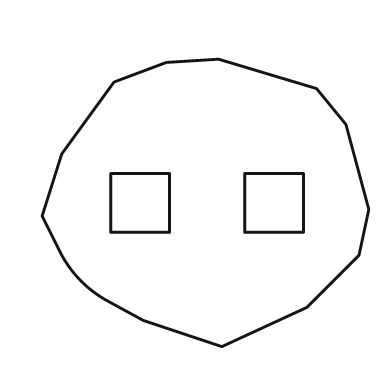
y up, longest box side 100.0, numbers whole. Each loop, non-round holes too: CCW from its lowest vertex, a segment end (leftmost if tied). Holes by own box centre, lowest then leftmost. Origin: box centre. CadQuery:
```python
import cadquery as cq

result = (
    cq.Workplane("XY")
    .moveTo(5.0, -44.0)
    .lineTo(31.0, -32.0)
    .lineTo(47.0, -16.0)
    .lineTo(50.0, -2.0)
    .lineTo(43.0, 24.0)
    .lineTo(34.0, 35.0)
    .lineTo(4.0, 44.0)
    .lineTo(-12.0, 43.0)
    .lineTo(-28.0, 37.0)
    .lineTo(-44.0, 15.0)
    .lineTo(-50.0, -4.0)
    .lineTo(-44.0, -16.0)
    .threePointArc((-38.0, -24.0), (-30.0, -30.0))
    .lineTo(-19.0, -36.0)
    .close()
    .moveTo(-29.0, -9.0)
    .lineTo(-11.0, -9.0)
    .lineTo(-11.0, 9.0)
    .lineTo(-29.0, 9.0)
    .close()
    .moveTo(12.0, -9.0)
    .lineTo(30.0, -9.0)
    .lineTo(30.0, 9.0)
    .lineTo(12.0, 9.0)
    .close()
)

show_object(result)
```